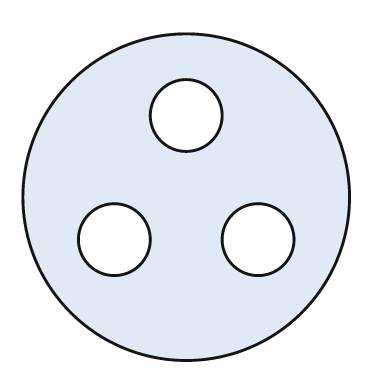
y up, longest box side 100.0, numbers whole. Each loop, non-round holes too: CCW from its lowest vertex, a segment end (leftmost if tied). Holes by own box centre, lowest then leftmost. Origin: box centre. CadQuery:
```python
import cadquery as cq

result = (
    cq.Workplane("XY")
    .moveTo(0.0, 0.0)
    .circle(50.0)
    .moveTo(-22.0, -13.0)
    .circle(11.0)
    .moveTo(22.0, -13.0)
    .circle(11.0)
    .moveTo(0.0, 25.0)
    .circle(11.0)
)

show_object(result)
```